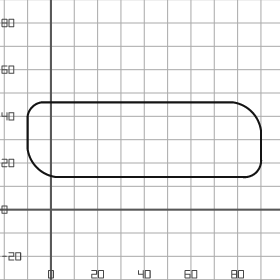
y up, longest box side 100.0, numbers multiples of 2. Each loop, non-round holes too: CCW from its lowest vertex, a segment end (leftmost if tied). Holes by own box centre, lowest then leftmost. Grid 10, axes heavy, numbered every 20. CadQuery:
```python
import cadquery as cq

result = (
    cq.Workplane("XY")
    .moveTo(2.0, 14.0)
    .lineTo(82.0, 14.0)
    .threePointArc((88.0, 16.0), (90.0, 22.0))
    .lineTo(90.0, 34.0)
    .threePointArc((86.0, 42.0), (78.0, 46.0))
    .lineTo(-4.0, 46.0)
    .threePointArc((-8.0, 44.0), (-10.0, 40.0))
    .lineTo(-10.0, 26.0)
    .threePointArc((-6.0, 18.0), (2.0, 14.0))
    .close()
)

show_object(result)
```